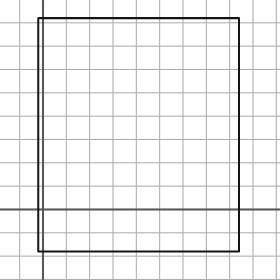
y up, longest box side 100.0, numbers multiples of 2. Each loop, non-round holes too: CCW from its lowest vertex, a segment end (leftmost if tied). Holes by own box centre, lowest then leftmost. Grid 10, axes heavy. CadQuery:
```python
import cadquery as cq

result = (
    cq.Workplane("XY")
    .moveTo(-2.0, -18.0)
    .lineTo(84.0, -18.0)
    .lineTo(84.0, 82.0)
    .lineTo(-2.0, 82.0)
    .close()
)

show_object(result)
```